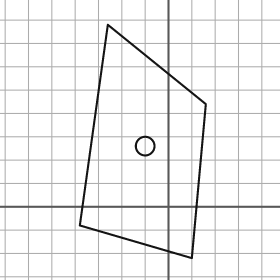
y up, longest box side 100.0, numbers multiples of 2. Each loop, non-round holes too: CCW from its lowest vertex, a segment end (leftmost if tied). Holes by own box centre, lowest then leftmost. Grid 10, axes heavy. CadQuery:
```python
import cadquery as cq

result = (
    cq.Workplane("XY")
    .moveTo(10.0, -22.0)
    .lineTo(16.0, 44.0)
    .lineTo(-26.0, 78.0)
    .lineTo(-38.0, -8.0)
    .close()
    .moveTo(-10.0, 26.0)
    .circle(4.0)
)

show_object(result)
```